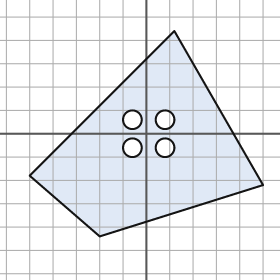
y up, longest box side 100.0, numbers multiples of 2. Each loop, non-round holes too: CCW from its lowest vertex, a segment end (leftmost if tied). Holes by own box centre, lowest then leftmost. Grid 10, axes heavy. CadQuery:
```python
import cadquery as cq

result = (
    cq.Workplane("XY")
    .moveTo(-20.0, -44.0)
    .lineTo(50.0, -22.0)
    .lineTo(12.0, 44.0)
    .lineTo(-50.0, -18.0)
    .close()
    .moveTo(-6.0, -6.0)
    .circle(4.0)
    .moveTo(8.0, -6.0)
    .circle(4.0)
    .moveTo(-6.0, 6.0)
    .circle(4.0)
    .moveTo(8.0, 6.0)
    .circle(4.0)
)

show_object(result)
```